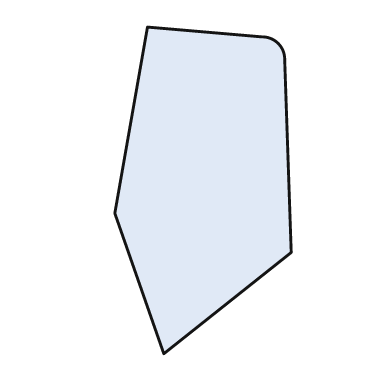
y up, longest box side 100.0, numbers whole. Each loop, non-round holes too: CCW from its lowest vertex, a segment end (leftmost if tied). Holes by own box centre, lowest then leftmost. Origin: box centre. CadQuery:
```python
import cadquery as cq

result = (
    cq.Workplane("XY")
    .moveTo(-12.0, -50.0)
    .lineTo(27.0, -19.0)
    .lineTo(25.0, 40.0)
    .threePointArc((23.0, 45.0), (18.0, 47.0))
    .lineTo(-17.0, 50.0)
    .lineTo(-27.0, -7.0)
    .close()
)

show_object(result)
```